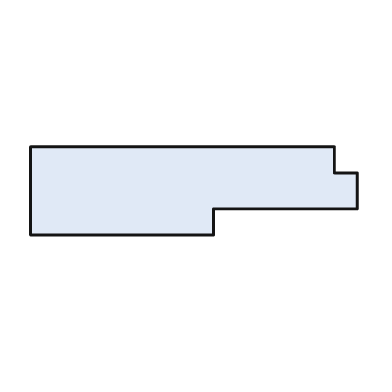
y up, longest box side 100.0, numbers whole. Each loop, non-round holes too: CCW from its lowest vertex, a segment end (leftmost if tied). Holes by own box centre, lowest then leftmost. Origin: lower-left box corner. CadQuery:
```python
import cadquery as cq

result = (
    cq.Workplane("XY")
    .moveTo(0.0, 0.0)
    .lineTo(56.0, 0.0)
    .lineTo(56.0, 8.0)
    .lineTo(100.0, 8.0)
    .lineTo(100.0, 19.0)
    .lineTo(93.0, 19.0)
    .lineTo(93.0, 27.0)
    .lineTo(0.0, 27.0)
    .close()
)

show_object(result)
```